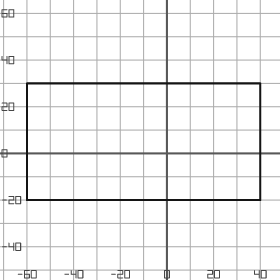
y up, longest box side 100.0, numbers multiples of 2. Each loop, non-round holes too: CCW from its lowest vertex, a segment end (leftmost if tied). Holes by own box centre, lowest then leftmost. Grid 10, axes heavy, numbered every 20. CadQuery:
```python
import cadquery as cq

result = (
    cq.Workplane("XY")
    .moveTo(-60.0, -20.0)
    .lineTo(40.0, -20.0)
    .lineTo(40.0, 30.0)
    .lineTo(-60.0, 30.0)
    .close()
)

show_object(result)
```